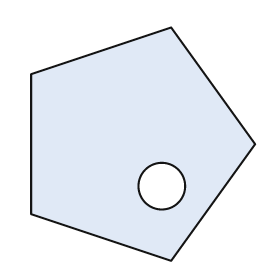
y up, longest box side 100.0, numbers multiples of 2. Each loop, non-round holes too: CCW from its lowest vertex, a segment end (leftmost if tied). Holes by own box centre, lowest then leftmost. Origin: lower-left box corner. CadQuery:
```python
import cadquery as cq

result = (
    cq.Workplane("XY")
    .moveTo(60.0, 0.0)
    .lineTo(96.0, 50.0)
    .lineTo(60.0, 100.0)
    .lineTo(0.0, 80.0)
    .lineTo(0.0, 20.0)
    .close()
    .moveTo(56.0, 32.0)
    .circle(10.0)
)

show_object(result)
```